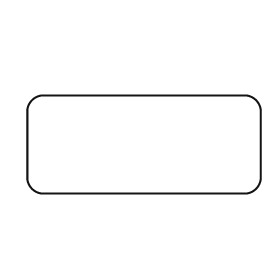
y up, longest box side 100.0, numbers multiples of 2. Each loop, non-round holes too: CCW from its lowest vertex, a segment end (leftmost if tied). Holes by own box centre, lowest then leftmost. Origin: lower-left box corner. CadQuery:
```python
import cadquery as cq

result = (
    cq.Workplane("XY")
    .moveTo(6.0, 0.0)
    .lineTo(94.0, 0.0)
    .threePointArc((98.0, 2.0), (100.0, 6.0))
    .lineTo(100.0, 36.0)
    .threePointArc((98.0, 40.0), (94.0, 42.0))
    .lineTo(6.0, 42.0)
    .threePointArc((2.0, 40.0), (0.0, 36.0))
    .lineTo(0.0, 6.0)
    .threePointArc((2.0, 2.0), (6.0, 0.0))
    .close()
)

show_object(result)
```